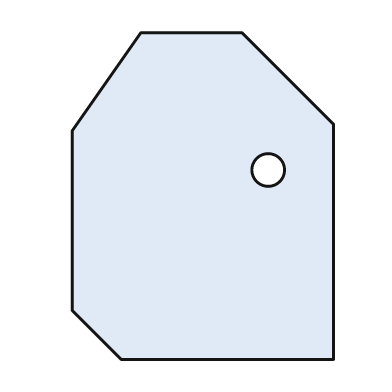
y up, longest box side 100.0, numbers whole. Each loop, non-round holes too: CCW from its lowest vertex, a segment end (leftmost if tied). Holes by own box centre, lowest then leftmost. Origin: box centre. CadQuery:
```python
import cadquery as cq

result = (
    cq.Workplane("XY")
    .moveTo(-25.0, -50.0)
    .lineTo(40.0, -50.0)
    .lineTo(40.0, 22.0)
    .lineTo(12.0, 50.0)
    .lineTo(-19.0, 50.0)
    .lineTo(-40.0, 20.0)
    .lineTo(-40.0, -35.0)
    .close()
    .moveTo(20.0, 8.0)
    .circle(5.0)
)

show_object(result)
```